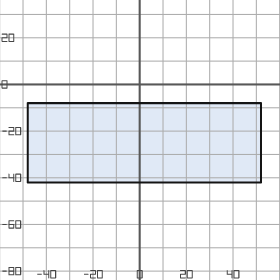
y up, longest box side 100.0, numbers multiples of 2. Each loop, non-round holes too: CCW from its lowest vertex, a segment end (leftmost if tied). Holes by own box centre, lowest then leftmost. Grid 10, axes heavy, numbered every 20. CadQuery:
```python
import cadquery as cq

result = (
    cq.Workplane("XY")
    .moveTo(-48.0, -42.0)
    .lineTo(52.0, -42.0)
    .lineTo(52.0, -8.0)
    .lineTo(-48.0, -8.0)
    .close()
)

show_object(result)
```